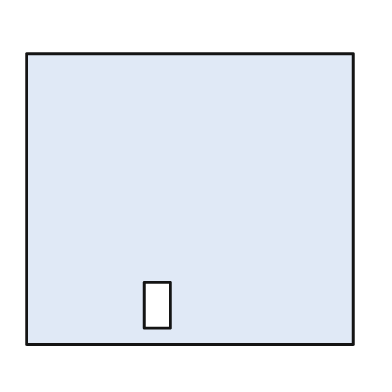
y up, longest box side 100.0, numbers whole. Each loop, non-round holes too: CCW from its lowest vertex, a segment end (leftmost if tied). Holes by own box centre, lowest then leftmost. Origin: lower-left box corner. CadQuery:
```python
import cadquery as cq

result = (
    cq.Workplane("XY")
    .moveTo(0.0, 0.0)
    .lineTo(100.0, 0.0)
    .lineTo(100.0, 89.0)
    .lineTo(0.0, 89.0)
    .close()
    .moveTo(36.0, 5.0)
    .lineTo(44.0, 5.0)
    .lineTo(44.0, 19.0)
    .lineTo(36.0, 19.0)
    .close()
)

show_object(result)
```